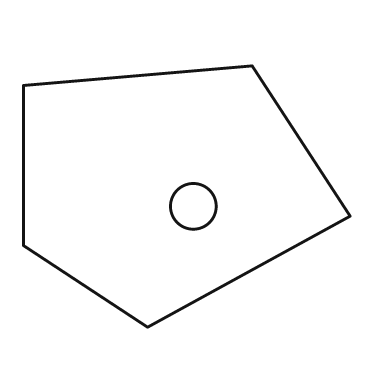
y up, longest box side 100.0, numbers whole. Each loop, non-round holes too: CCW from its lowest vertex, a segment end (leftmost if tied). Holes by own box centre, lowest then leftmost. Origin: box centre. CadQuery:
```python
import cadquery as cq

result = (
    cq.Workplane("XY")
    .moveTo(-12.0, -40.0)
    .lineTo(50.0, -6.0)
    .lineTo(20.0, 40.0)
    .lineTo(-50.0, 34.0)
    .lineTo(-50.0, -15.0)
    .close()
    .moveTo(2.0, -3.0)
    .circle(7.0)
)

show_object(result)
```